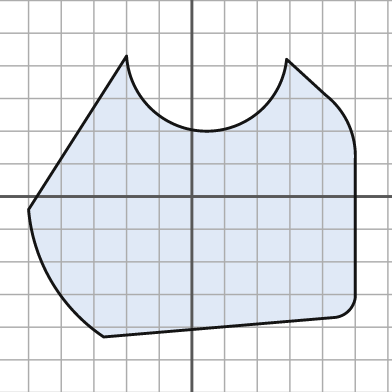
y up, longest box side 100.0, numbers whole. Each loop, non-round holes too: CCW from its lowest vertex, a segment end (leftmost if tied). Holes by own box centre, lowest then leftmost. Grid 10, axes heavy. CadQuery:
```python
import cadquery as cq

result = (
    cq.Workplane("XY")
    .moveTo(-27.0, -43.0)
    .lineTo(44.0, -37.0)
    .threePointArc((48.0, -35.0), (50.0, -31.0))
    .lineTo(50.0, 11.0)
    .threePointArc((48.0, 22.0), (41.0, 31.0))
    .lineTo(29.0, 42.0)
    .threePointArc((4.0, 20.0), (-20.0, 43.0))
    .lineTo(-50.0, -4.0)
    .threePointArc((-43.0, -26.0), (-27.0, -43.0))
    .close()
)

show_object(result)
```